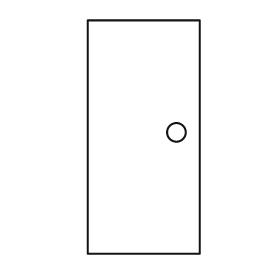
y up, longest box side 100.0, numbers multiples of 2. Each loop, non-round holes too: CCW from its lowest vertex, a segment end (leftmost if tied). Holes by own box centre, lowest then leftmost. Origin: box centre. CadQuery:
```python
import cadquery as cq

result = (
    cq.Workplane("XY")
    .moveTo(-24.0, -50.0)
    .lineTo(24.0, -50.0)
    .lineTo(24.0, 50.0)
    .lineTo(-24.0, 50.0)
    .close()
    .moveTo(14.0, 2.0)
    .circle(4.0)
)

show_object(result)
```